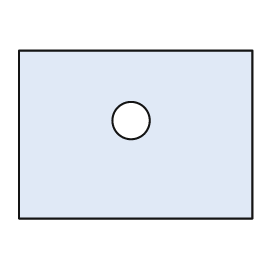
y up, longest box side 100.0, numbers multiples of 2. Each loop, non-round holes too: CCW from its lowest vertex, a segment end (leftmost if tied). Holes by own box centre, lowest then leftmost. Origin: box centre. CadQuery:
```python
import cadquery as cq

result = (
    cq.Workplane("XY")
    .moveTo(-50.0, -36.0)
    .lineTo(50.0, -36.0)
    .lineTo(50.0, 36.0)
    .lineTo(-50.0, 36.0)
    .close()
    .moveTo(-2.0, 6.0)
    .circle(8.0)
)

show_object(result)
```